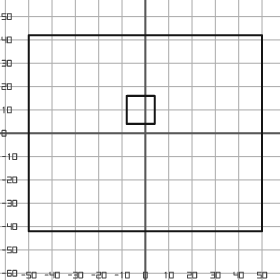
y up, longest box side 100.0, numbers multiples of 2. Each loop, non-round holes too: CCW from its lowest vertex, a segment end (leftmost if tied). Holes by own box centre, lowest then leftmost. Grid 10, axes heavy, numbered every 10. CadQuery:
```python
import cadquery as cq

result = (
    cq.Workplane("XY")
    .moveTo(-50.0, -42.0)
    .lineTo(50.0, -42.0)
    .lineTo(50.0, 42.0)
    .lineTo(-50.0, 42.0)
    .close()
    .moveTo(-8.0, 4.0)
    .lineTo(4.0, 4.0)
    .lineTo(4.0, 16.0)
    .lineTo(-8.0, 16.0)
    .close()
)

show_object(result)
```